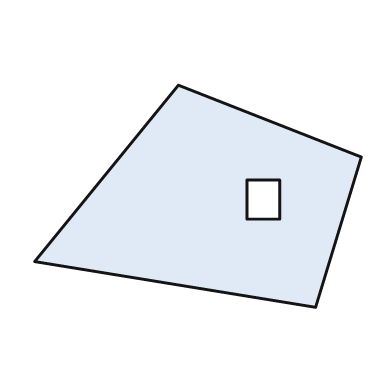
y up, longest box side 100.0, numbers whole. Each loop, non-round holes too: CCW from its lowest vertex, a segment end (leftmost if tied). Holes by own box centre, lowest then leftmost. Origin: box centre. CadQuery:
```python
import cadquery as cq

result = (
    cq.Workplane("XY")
    .moveTo(36.0, -34.0)
    .lineTo(50.0, 12.0)
    .lineTo(-6.0, 34.0)
    .lineTo(-50.0, -20.0)
    .close()
    .moveTo(15.0, -7.0)
    .lineTo(25.0, -7.0)
    .lineTo(25.0, 5.0)
    .lineTo(15.0, 5.0)
    .close()
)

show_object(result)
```